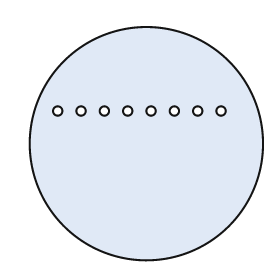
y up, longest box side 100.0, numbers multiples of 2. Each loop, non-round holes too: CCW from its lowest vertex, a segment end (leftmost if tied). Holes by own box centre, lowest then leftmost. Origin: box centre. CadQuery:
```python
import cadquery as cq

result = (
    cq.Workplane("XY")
    .moveTo(0.0, 0.0)
    .circle(50.0)
    .moveTo(-38.0, 14.0)
    .circle(2.0)
    .moveTo(-28.0, 14.0)
    .circle(2.0)
    .moveTo(-18.0, 14.0)
    .circle(2.0)
    .moveTo(-8.0, 14.0)
    .circle(2.0)
    .moveTo(2.0, 14.0)
    .circle(2.0)
    .moveTo(12.0, 14.0)
    .circle(2.0)
    .moveTo(22.0, 14.0)
    .circle(2.0)
    .moveTo(32.0, 14.0)
    .circle(2.0)
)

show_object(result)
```